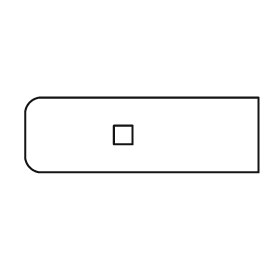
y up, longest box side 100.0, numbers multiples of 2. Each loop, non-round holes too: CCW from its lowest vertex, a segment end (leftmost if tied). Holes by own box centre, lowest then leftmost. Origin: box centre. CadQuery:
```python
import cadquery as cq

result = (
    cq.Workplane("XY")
    .moveTo(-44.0, -16.0)
    .lineTo(50.0, -16.0)
    .lineTo(50.0, 16.0)
    .lineTo(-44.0, 16.0)
    .threePointArc((-48.0, 14.0), (-50.0, 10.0))
    .lineTo(-50.0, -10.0)
    .threePointArc((-48.0, -14.0), (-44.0, -16.0))
    .close()
    .moveTo(-12.0, -4.0)
    .lineTo(-4.0, -4.0)
    .lineTo(-4.0, 4.0)
    .lineTo(-12.0, 4.0)
    .close()
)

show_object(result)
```